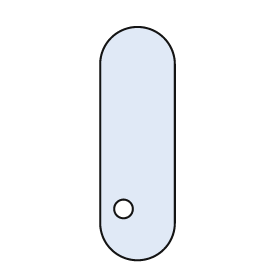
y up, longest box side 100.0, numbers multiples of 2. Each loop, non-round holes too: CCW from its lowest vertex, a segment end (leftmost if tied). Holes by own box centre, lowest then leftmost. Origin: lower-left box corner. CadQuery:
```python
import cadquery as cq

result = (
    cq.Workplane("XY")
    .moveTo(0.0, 16.0)
    .threePointArc((16.0, 0.0), (32.0, 16.0))
    .lineTo(32.0, 84.0)
    .threePointArc((16.0, 100.0), (0.0, 84.0))
    .close()
    .moveTo(10.0, 22.0)
    .circle(4.0)
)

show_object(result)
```